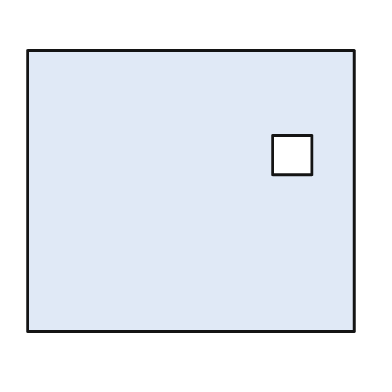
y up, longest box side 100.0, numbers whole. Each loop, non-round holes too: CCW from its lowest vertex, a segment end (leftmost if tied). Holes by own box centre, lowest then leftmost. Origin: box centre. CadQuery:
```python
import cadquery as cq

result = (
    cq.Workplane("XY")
    .moveTo(-50.0, -43.0)
    .lineTo(50.0, -43.0)
    .lineTo(50.0, 43.0)
    .lineTo(-50.0, 43.0)
    .close()
    .moveTo(25.0, 5.0)
    .lineTo(37.0, 5.0)
    .lineTo(37.0, 17.0)
    .lineTo(25.0, 17.0)
    .close()
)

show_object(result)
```